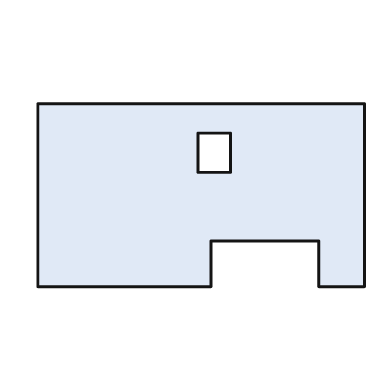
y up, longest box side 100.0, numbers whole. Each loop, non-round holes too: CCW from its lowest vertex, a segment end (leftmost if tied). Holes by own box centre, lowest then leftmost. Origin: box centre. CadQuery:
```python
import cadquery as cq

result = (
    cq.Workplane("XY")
    .moveTo(-50.0, -28.0)
    .lineTo(3.0, -28.0)
    .lineTo(3.0, -14.0)
    .lineTo(36.0, -14.0)
    .lineTo(36.0, -28.0)
    .lineTo(50.0, -28.0)
    .lineTo(50.0, 28.0)
    .lineTo(-50.0, 28.0)
    .close()
    .moveTo(-1.0, 7.0)
    .lineTo(9.0, 7.0)
    .lineTo(9.0, 19.0)
    .lineTo(-1.0, 19.0)
    .close()
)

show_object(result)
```